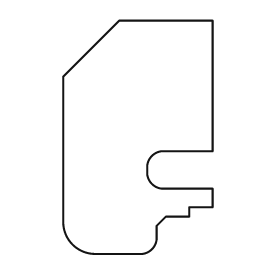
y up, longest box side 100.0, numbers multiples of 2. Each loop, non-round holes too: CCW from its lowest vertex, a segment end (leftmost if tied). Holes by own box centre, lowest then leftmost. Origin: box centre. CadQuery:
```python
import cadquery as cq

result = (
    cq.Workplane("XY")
    .moveTo(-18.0, -50.0)
    .lineTo(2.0, -50.0)
    .threePointArc((6.0, -48.0), (8.0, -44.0))
    .lineTo(8.0, -38.0)
    .lineTo(12.0, -34.0)
    .lineTo(22.0, -34.0)
    .lineTo(22.0, -30.0)
    .lineTo(32.0, -30.0)
    .lineTo(32.0, -22.0)
    .lineTo(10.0, -22.0)
    .threePointArc((6.0, -20.0), (4.0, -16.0))
    .lineTo(4.0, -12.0)
    .threePointArc((6.0, -8.0), (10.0, -6.0))
    .lineTo(32.0, -6.0)
    .lineTo(32.0, 50.0)
    .lineTo(-8.0, 50.0)
    .lineTo(-32.0, 26.0)
    .lineTo(-32.0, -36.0)
    .threePointArc((-28.0, -46.0), (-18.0, -50.0))
    .close()
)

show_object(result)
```